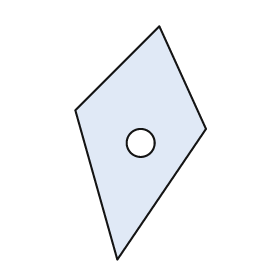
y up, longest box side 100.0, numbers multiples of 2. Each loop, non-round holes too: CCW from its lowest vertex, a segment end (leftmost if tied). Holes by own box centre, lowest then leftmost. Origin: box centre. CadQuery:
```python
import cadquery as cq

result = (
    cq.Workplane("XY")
    .moveTo(-10.0, -50.0)
    .lineTo(28.0, 6.0)
    .lineTo(8.0, 50.0)
    .lineTo(-28.0, 14.0)
    .close()
    .moveTo(0.0, 0.0)
    .circle(6.0)
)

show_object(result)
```